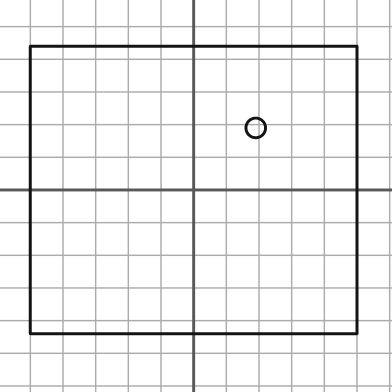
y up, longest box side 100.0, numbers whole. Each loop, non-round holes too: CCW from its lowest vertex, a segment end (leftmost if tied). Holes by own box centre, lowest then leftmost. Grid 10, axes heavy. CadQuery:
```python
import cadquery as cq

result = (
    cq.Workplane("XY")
    .moveTo(-50.0, -44.0)
    .lineTo(50.0, -44.0)
    .lineTo(50.0, 44.0)
    .lineTo(-50.0, 44.0)
    .close()
    .moveTo(19.0, 19.0)
    .circle(3.0)
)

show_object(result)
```